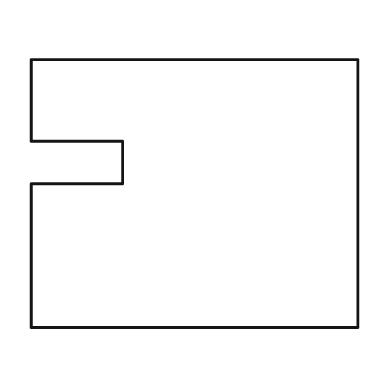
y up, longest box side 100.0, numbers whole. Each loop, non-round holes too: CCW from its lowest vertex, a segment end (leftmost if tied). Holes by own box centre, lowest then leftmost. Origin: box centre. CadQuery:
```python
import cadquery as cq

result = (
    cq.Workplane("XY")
    .moveTo(-50.0, -41.0)
    .lineTo(50.0, -41.0)
    .lineTo(50.0, 41.0)
    .lineTo(-50.0, 41.0)
    .lineTo(-50.0, 16.0)
    .lineTo(-22.0, 16.0)
    .lineTo(-22.0, 3.0)
    .lineTo(-50.0, 3.0)
    .close()
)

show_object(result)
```